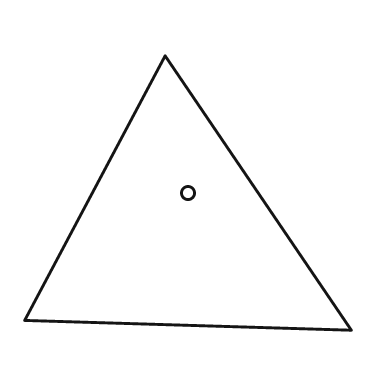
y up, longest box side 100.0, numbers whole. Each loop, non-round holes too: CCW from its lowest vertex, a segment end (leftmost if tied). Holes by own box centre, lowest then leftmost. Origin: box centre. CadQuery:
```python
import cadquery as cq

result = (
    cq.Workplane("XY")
    .moveTo(50.0, -42.0)
    .lineTo(-7.0, 42.0)
    .lineTo(-50.0, -39.0)
    .close()
    .moveTo(0.0, 0.0)
    .circle(2.0)
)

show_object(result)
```